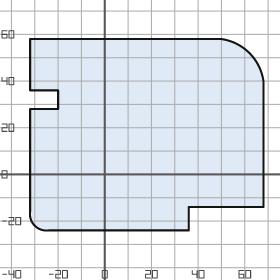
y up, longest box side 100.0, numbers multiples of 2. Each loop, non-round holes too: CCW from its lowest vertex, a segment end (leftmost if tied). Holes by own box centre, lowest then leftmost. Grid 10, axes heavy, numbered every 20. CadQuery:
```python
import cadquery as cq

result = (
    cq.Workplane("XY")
    .moveTo(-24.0, -24.0)
    .lineTo(36.0, -24.0)
    .lineTo(36.0, -14.0)
    .lineTo(68.0, -14.0)
    .lineTo(68.0, 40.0)
    .threePointArc((62.0, 52.0), (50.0, 58.0))
    .lineTo(-32.0, 58.0)
    .lineTo(-32.0, 36.0)
    .lineTo(-20.0, 36.0)
    .lineTo(-20.0, 28.0)
    .lineTo(-32.0, 28.0)
    .lineTo(-32.0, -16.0)
    .threePointArc((-30.0, -22.0), (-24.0, -24.0))
    .close()
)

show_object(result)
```